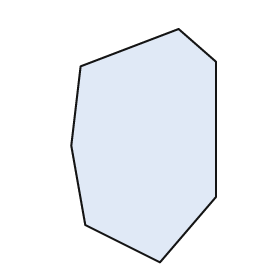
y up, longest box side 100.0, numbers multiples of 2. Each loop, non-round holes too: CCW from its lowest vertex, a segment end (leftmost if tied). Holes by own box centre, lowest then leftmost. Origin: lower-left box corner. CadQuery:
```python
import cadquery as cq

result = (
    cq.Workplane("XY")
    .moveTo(38.0, 0.0)
    .lineTo(62.0, 28.0)
    .lineTo(62.0, 86.0)
    .lineTo(46.0, 100.0)
    .lineTo(4.0, 84.0)
    .lineTo(0.0, 50.0)
    .lineTo(6.0, 16.0)
    .close()
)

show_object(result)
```